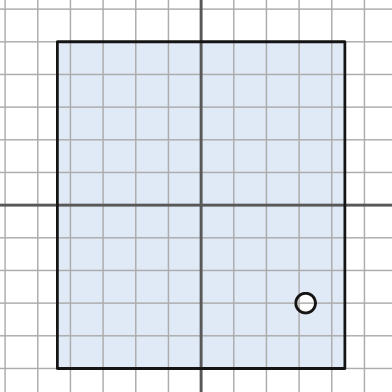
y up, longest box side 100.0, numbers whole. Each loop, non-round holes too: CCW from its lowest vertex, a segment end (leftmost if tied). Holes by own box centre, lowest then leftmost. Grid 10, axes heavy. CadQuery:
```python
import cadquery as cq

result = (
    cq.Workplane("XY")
    .moveTo(-44.0, -50.0)
    .lineTo(44.0, -50.0)
    .lineTo(44.0, 50.0)
    .lineTo(-44.0, 50.0)
    .close()
    .moveTo(32.0, -30.0)
    .circle(3.0)
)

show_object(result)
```